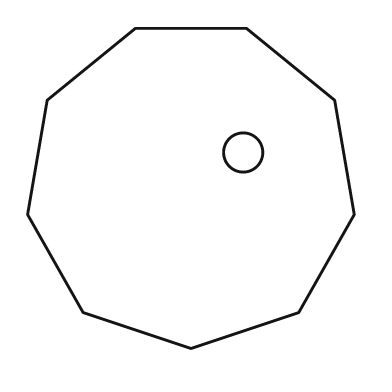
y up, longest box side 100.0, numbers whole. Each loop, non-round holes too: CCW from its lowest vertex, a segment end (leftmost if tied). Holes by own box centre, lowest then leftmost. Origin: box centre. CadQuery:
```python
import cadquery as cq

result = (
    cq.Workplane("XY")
    .moveTo(0.0, -49.0)
    .lineTo(33.0, -38.0)
    .lineTo(50.0, -8.0)
    .lineTo(44.0, 27.0)
    .lineTo(17.0, 49.0)
    .lineTo(-17.0, 49.0)
    .lineTo(-44.0, 27.0)
    .lineTo(-50.0, -8.0)
    .lineTo(-33.0, -38.0)
    .close()
    .moveTo(16.0, 11.0)
    .circle(6.0)
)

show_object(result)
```